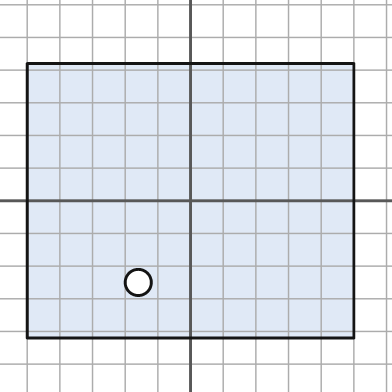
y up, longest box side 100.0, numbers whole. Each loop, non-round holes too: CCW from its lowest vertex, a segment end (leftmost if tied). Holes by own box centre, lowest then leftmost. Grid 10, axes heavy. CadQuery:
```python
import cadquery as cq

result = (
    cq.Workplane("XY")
    .moveTo(-50.0, -42.0)
    .lineTo(50.0, -42.0)
    .lineTo(50.0, 42.0)
    .lineTo(-50.0, 42.0)
    .close()
    .moveTo(-16.0, -25.0)
    .circle(4.0)
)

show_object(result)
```